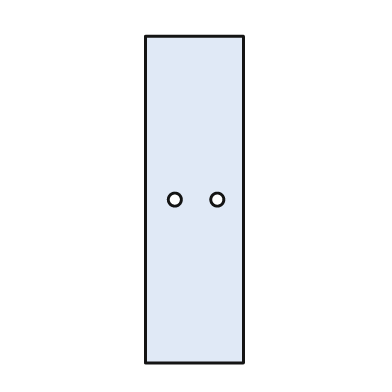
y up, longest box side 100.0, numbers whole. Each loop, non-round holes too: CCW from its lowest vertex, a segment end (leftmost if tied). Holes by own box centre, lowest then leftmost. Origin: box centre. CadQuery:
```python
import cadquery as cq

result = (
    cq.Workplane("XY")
    .moveTo(-15.0, -50.0)
    .lineTo(15.0, -50.0)
    .lineTo(15.0, 50.0)
    .lineTo(-15.0, 50.0)
    .close()
    .moveTo(-6.0, 0.0)
    .circle(2.0)
    .moveTo(7.0, 0.0)
    .circle(2.0)
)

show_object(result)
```